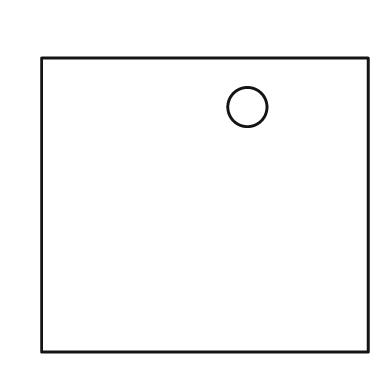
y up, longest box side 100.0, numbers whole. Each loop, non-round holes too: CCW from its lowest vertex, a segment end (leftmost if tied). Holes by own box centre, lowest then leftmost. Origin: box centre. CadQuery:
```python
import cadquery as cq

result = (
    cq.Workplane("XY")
    .moveTo(-50.0, -45.0)
    .lineTo(50.0, -45.0)
    .lineTo(50.0, 45.0)
    .lineTo(-50.0, 45.0)
    .close()
    .moveTo(13.0, 30.0)
    .circle(6.0)
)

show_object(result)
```